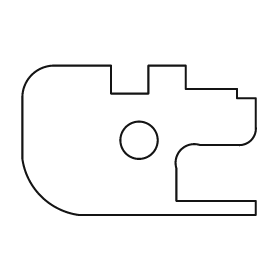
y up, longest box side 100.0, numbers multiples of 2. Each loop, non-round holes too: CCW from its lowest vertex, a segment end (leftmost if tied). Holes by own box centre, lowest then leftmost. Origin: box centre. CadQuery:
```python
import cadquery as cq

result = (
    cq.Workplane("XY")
    .moveTo(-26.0, -32.0)
    .lineTo(50.0, -32.0)
    .lineTo(50.0, -26.0)
    .lineTo(16.0, -26.0)
    .lineTo(16.0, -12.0)
    .threePointArc((18.0, -4.0), (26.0, -2.0))
    .lineTo(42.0, -2.0)
    .threePointArc((48.0, 0.0), (50.0, 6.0))
    .lineTo(50.0, 18.0)
    .lineTo(42.0, 18.0)
    .lineTo(42.0, 22.0)
    .lineTo(20.0, 22.0)
    .lineTo(20.0, 32.0)
    .lineTo(4.0, 32.0)
    .lineTo(4.0, 20.0)
    .lineTo(-12.0, 20.0)
    .lineTo(-12.0, 32.0)
    .lineTo(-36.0, 32.0)
    .threePointArc((-46.0, 28.0), (-50.0, 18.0))
    .lineTo(-50.0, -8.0)
    .threePointArc((-42.0, -24.0), (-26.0, -32.0))
    .close()
    .moveTo(0.0, 0.0)
    .circle(8.0)
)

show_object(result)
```